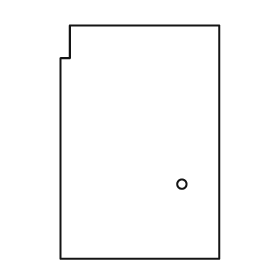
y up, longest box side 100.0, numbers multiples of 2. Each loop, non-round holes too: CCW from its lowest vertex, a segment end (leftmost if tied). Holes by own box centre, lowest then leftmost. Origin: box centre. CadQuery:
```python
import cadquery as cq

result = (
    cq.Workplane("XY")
    .moveTo(-34.0, -50.0)
    .lineTo(34.0, -50.0)
    .lineTo(34.0, 50.0)
    .lineTo(-30.0, 50.0)
    .lineTo(-30.0, 36.0)
    .lineTo(-34.0, 36.0)
    .close()
    .moveTo(18.0, -18.0)
    .circle(2.0)
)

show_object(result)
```